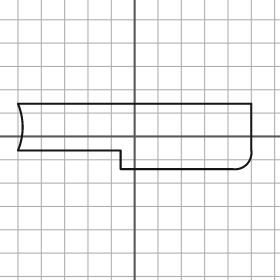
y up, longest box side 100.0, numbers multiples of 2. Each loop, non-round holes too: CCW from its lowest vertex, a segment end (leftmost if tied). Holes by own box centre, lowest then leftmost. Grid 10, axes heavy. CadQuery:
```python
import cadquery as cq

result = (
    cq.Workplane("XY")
    .moveTo(-6.0, -14.0)
    .lineTo(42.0, -14.0)
    .threePointArc((48.0, -12.0), (50.0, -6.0))
    .lineTo(50.0, 14.0)
    .lineTo(-50.0, 14.0)
    .threePointArc((-48.0, 4.0), (-50.0, -6.0))
    .lineTo(-6.0, -6.0)
    .close()
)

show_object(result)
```